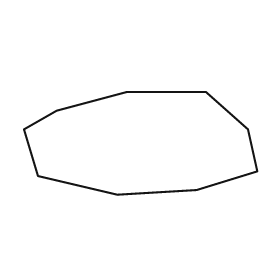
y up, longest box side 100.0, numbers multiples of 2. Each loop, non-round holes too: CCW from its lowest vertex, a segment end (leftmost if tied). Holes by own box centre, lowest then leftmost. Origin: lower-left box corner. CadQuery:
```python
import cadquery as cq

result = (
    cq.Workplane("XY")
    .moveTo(40.0, 0.0)
    .lineTo(74.0, 2.0)
    .lineTo(100.0, 10.0)
    .lineTo(96.0, 28.0)
    .lineTo(78.0, 44.0)
    .lineTo(44.0, 44.0)
    .lineTo(14.0, 36.0)
    .lineTo(0.0, 28.0)
    .lineTo(6.0, 8.0)
    .close()
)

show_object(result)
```